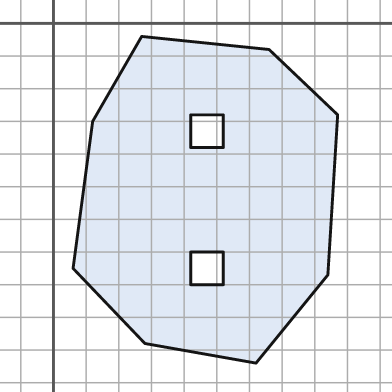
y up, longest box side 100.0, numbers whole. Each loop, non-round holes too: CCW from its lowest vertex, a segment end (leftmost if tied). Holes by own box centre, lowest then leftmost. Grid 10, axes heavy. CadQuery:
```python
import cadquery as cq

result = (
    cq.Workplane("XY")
    .moveTo(62.0, -104.0)
    .lineTo(84.0, -77.0)
    .lineTo(87.0, -28.0)
    .lineTo(66.0, -8.0)
    .lineTo(27.0, -4.0)
    .lineTo(12.0, -30.0)
    .lineTo(6.0, -75.0)
    .lineTo(28.0, -98.0)
    .close()
    .moveTo(42.0, -80.0)
    .lineTo(52.0, -80.0)
    .lineTo(52.0, -70.0)
    .lineTo(42.0, -70.0)
    .close()
    .moveTo(42.0, -38.0)
    .lineTo(52.0, -38.0)
    .lineTo(52.0, -28.0)
    .lineTo(42.0, -28.0)
    .close()
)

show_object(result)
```